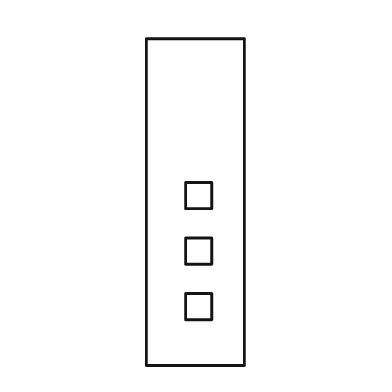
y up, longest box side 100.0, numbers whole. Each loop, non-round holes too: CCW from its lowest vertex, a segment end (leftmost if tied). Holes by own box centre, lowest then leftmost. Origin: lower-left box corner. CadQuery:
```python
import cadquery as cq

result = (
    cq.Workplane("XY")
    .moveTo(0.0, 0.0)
    .lineTo(30.0, 0.0)
    .lineTo(30.0, 100.0)
    .lineTo(0.0, 100.0)
    .close()
    .moveTo(12.0, 14.0)
    .lineTo(20.0, 14.0)
    .lineTo(20.0, 22.0)
    .lineTo(12.0, 22.0)
    .close()
    .moveTo(12.0, 31.0)
    .lineTo(20.0, 31.0)
    .lineTo(20.0, 39.0)
    .lineTo(12.0, 39.0)
    .close()
    .moveTo(12.0, 48.0)
    .lineTo(20.0, 48.0)
    .lineTo(20.0, 56.0)
    .lineTo(12.0, 56.0)
    .close()
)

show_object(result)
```